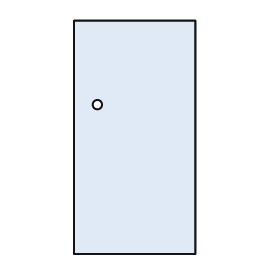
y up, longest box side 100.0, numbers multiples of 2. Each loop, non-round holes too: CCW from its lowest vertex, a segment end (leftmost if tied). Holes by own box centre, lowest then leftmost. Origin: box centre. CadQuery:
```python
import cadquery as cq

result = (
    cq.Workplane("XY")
    .moveTo(-26.0, -50.0)
    .lineTo(26.0, -50.0)
    .lineTo(26.0, 50.0)
    .lineTo(-26.0, 50.0)
    .close()
    .moveTo(-16.0, 14.0)
    .circle(2.0)
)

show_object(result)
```